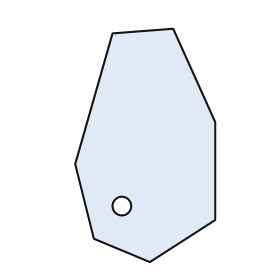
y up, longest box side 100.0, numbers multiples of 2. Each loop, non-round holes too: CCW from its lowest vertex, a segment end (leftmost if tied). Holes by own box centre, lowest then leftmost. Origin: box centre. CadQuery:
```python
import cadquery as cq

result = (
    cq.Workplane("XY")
    .moveTo(2.0, -50.0)
    .lineTo(30.0, -32.0)
    .lineTo(30.0, 10.0)
    .lineTo(12.0, 50.0)
    .lineTo(-14.0, 48.0)
    .lineTo(-30.0, -8.0)
    .lineTo(-22.0, -40.0)
    .close()
    .moveTo(-10.0, -26.0)
    .circle(4.0)
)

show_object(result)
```